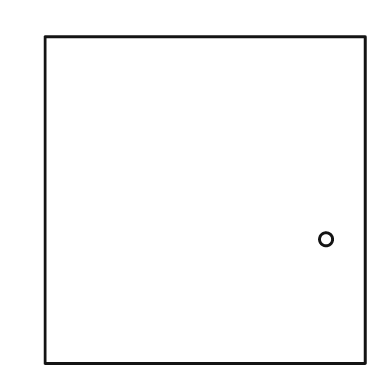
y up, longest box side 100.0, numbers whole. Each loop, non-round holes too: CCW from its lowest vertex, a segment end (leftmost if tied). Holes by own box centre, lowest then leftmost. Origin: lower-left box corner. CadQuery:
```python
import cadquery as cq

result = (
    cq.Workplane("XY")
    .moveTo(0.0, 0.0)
    .lineTo(98.0, 0.0)
    .lineTo(98.0, 100.0)
    .lineTo(0.0, 100.0)
    .close()
    .moveTo(86.0, 38.0)
    .circle(2.0)
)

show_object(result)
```